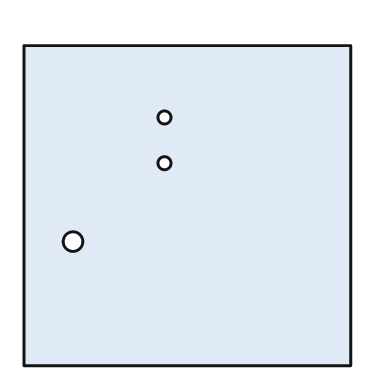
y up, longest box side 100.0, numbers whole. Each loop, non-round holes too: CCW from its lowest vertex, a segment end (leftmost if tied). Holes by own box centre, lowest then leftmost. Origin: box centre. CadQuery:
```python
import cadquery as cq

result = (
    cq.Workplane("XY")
    .moveTo(-50.0, -49.0)
    .lineTo(50.0, -49.0)
    .lineTo(50.0, 49.0)
    .lineTo(-50.0, 49.0)
    .close()
    .moveTo(-35.0, -11.0)
    .circle(3.0)
    .moveTo(-7.0, 13.0)
    .circle(2.0)
    .moveTo(-7.0, 27.0)
    .circle(2.0)
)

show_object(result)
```